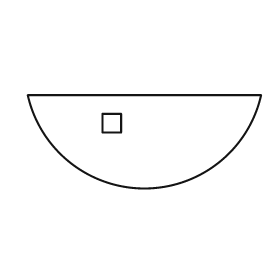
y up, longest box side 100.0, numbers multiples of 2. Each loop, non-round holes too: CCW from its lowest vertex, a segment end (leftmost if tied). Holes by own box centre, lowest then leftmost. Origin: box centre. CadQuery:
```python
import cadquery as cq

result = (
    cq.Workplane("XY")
    .moveTo(-50.0, 20.0)
    .threePointArc((0.0, -20.0), (50.0, 20.0))
    .close()
    .moveTo(-18.0, 4.0)
    .lineTo(-10.0, 4.0)
    .lineTo(-10.0, 12.0)
    .lineTo(-18.0, 12.0)
    .close()
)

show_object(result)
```